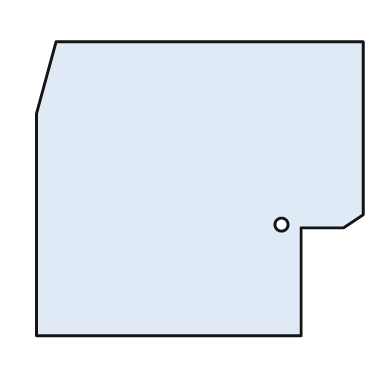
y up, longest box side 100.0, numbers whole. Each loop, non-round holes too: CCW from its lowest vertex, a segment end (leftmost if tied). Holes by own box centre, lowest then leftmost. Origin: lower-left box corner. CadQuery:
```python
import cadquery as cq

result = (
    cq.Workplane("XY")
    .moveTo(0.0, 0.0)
    .lineTo(81.0, 0.0)
    .lineTo(81.0, 33.0)
    .lineTo(94.0, 33.0)
    .lineTo(100.0, 37.0)
    .lineTo(100.0, 90.0)
    .lineTo(6.0, 90.0)
    .lineTo(0.0, 68.0)
    .close()
    .moveTo(75.0, 34.0)
    .circle(2.0)
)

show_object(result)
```